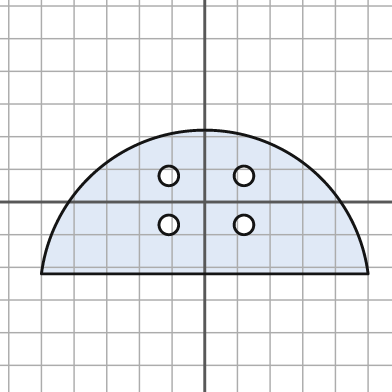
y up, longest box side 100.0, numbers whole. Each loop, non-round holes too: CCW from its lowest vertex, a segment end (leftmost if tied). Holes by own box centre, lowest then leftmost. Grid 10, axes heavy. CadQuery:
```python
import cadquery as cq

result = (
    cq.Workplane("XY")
    .moveTo(-50.0, -22.0)
    .lineTo(50.0, -22.0)
    .threePointArc((0.0, 22.0), (-50.0, -22.0))
    .close()
    .moveTo(-11.0, -7.0)
    .circle(3.0)
    .moveTo(12.0, -7.0)
    .circle(3.0)
    .moveTo(-11.0, 8.0)
    .circle(3.0)
    .moveTo(12.0, 8.0)
    .circle(3.0)
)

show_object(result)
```